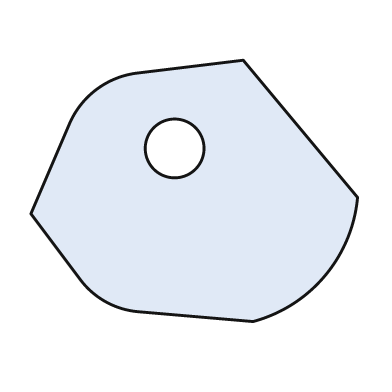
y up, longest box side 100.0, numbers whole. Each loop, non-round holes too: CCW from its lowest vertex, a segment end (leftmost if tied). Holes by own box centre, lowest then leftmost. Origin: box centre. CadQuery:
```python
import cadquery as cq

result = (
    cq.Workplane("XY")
    .moveTo(18.0, -40.0)
    .threePointArc((40.0, -26.0), (50.0, -2.0))
    .lineTo(15.0, 40.0)
    .lineTo(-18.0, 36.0)
    .threePointArc((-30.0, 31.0), (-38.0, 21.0))
    .lineTo(-50.0, -7.0)
    .lineTo(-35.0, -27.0)
    .threePointArc((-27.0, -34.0), (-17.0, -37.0))
    .close()
    .moveTo(-6.0, 13.0)
    .circle(9.0)
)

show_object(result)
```